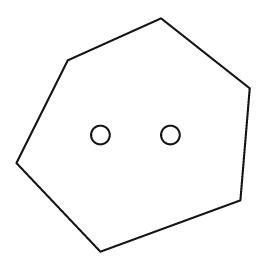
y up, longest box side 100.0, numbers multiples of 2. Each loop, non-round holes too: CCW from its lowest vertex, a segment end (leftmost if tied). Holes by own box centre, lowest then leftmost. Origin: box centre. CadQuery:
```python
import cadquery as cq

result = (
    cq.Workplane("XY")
    .moveTo(-14.0, -50.0)
    .lineTo(46.0, -28.0)
    .lineTo(50.0, 20.0)
    .lineTo(12.0, 50.0)
    .lineTo(-28.0, 32.0)
    .lineTo(-50.0, -12.0)
    .close()
    .moveTo(-14.0, 0.0)
    .circle(4.0)
    .moveTo(16.0, 0.0)
    .circle(4.0)
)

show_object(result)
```